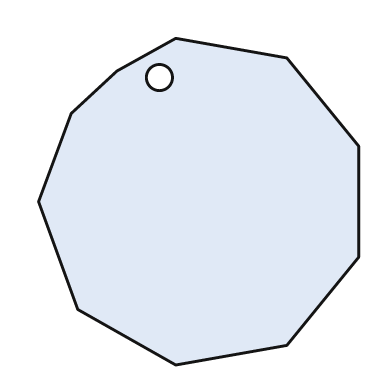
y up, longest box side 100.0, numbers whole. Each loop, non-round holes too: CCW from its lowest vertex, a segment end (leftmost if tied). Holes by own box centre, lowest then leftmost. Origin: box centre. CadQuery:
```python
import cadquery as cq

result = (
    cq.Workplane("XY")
    .moveTo(-7.0, -50.0)
    .lineTo(27.0, -44.0)
    .lineTo(49.0, -17.0)
    .lineTo(49.0, 17.0)
    .lineTo(27.0, 44.0)
    .lineTo(-7.0, 50.0)
    .lineTo(-25.0, 40.0)
    .lineTo(-39.0, 27.0)
    .lineTo(-49.0, 0.0)
    .lineTo(-37.0, -33.0)
    .close()
    .moveTo(-12.0, 38.0)
    .circle(4.0)
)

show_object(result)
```